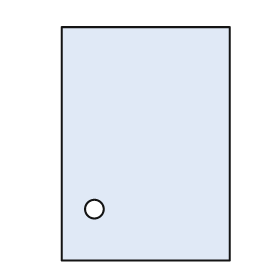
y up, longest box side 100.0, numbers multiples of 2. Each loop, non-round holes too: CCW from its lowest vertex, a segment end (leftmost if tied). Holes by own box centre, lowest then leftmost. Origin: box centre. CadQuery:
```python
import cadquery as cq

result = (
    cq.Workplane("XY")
    .moveTo(-36.0, -50.0)
    .lineTo(36.0, -50.0)
    .lineTo(36.0, 50.0)
    .lineTo(-36.0, 50.0)
    .close()
    .moveTo(-22.0, -28.0)
    .circle(4.0)
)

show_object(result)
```